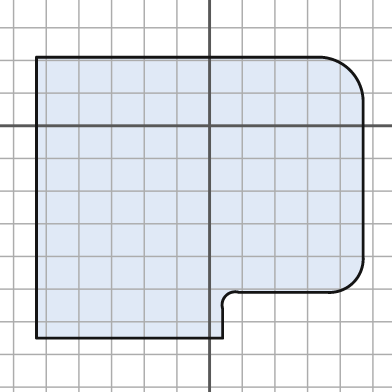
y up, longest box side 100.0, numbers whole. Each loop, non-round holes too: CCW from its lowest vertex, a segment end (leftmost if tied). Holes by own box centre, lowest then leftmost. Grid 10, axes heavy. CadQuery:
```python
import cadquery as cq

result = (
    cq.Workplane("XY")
    .moveTo(-53.0, -65.0)
    .lineTo(4.0, -65.0)
    .lineTo(4.0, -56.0)
    .threePointArc((5.0, -52.0), (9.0, -51.0))
    .lineTo(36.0, -51.0)
    .threePointArc((44.0, -48.0), (47.0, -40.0))
    .lineTo(47.0, 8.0)
    .threePointArc((43.0, 17.0), (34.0, 21.0))
    .lineTo(-53.0, 21.0)
    .close()
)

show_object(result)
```